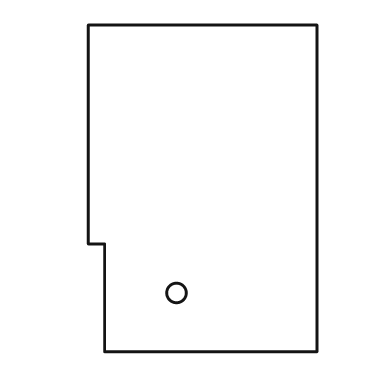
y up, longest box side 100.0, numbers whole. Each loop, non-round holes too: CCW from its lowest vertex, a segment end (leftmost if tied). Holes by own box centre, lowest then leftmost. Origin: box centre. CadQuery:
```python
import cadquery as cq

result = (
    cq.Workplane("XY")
    .moveTo(-30.0, -50.0)
    .lineTo(35.0, -50.0)
    .lineTo(35.0, 50.0)
    .lineTo(-35.0, 50.0)
    .lineTo(-35.0, -17.0)
    .lineTo(-30.0, -17.0)
    .close()
    .moveTo(-8.0, -32.0)
    .circle(3.0)
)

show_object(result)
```